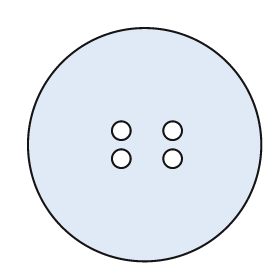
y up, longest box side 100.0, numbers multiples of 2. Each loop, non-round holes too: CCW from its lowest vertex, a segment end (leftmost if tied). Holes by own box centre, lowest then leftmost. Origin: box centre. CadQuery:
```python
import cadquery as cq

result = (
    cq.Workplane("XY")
    .moveTo(0.0, 0.0)
    .circle(50.0)
    .moveTo(-10.0, -6.0)
    .circle(4.0)
    .moveTo(12.0, -6.0)
    .circle(4.0)
    .moveTo(-10.0, 6.0)
    .circle(4.0)
    .moveTo(12.0, 6.0)
    .circle(4.0)
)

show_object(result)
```